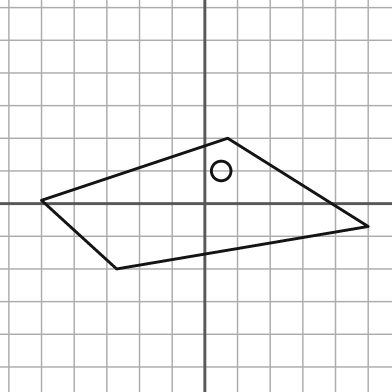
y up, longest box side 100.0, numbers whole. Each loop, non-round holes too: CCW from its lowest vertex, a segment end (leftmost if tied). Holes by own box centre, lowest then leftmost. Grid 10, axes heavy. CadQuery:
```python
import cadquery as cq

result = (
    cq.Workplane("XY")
    .moveTo(-27.0, -20.0)
    .lineTo(50.0, -7.0)
    .lineTo(7.0, 20.0)
    .lineTo(-50.0, 1.0)
    .close()
    .moveTo(5.0, 10.0)
    .circle(3.0)
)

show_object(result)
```